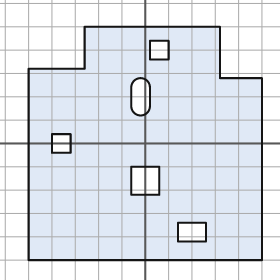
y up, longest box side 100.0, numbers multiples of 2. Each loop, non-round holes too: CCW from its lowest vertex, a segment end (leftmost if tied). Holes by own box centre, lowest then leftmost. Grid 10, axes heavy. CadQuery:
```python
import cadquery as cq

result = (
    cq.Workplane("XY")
    .moveTo(-50.0, -50.0)
    .lineTo(50.0, -50.0)
    .lineTo(50.0, 28.0)
    .lineTo(32.0, 28.0)
    .lineTo(32.0, 50.0)
    .lineTo(-26.0, 50.0)
    .lineTo(-26.0, 32.0)
    .lineTo(-50.0, 32.0)
    .close()
    .moveTo(14.0, -42.0)
    .lineTo(26.0, -42.0)
    .lineTo(26.0, -34.0)
    .lineTo(14.0, -34.0)
    .close()
    .moveTo(-6.0, -22.0)
    .lineTo(6.0, -22.0)
    .lineTo(6.0, -10.0)
    .lineTo(-6.0, -10.0)
    .close()
    .moveTo(-40.0, -4.0)
    .lineTo(-32.0, -4.0)
    .lineTo(-32.0, 4.0)
    .lineTo(-40.0, 4.0)
    .close()
    .moveTo(-6.0, 16.0)
    .threePointArc((-2.0, 12.0), (2.0, 16.0))
    .lineTo(2.0, 24.0)
    .threePointArc((-2.0, 28.0), (-6.0, 24.0))
    .close()
    .moveTo(2.0, 36.0)
    .lineTo(10.0, 36.0)
    .lineTo(10.0, 44.0)
    .lineTo(2.0, 44.0)
    .close()
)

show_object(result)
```